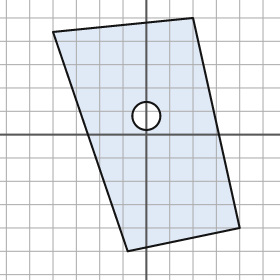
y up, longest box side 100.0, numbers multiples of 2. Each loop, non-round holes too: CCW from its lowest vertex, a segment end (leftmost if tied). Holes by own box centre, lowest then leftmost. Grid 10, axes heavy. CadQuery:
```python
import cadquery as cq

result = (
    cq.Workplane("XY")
    .moveTo(-8.0, -50.0)
    .lineTo(40.0, -40.0)
    .lineTo(20.0, 50.0)
    .lineTo(-40.0, 44.0)
    .close()
    .moveTo(0.0, 8.0)
    .circle(6.0)
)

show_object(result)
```